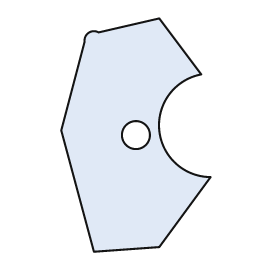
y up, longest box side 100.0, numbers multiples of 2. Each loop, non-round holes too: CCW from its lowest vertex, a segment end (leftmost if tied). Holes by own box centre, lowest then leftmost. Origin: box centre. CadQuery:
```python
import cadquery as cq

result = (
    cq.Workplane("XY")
    .moveTo(-18.0, -50.0)
    .lineTo(10.0, -48.0)
    .lineTo(32.0, -18.0)
    .threePointArc((10.0, 2.0), (28.0, 26.0))
    .lineTo(10.0, 50.0)
    .lineTo(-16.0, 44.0)
    .threePointArc((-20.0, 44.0), (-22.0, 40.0))
    .lineTo(-32.0, 2.0)
    .close()
    .moveTo(0.0, 0.0)
    .circle(6.0)
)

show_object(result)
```